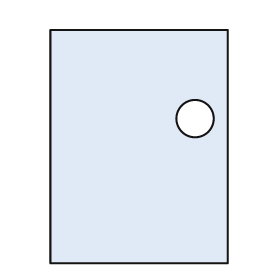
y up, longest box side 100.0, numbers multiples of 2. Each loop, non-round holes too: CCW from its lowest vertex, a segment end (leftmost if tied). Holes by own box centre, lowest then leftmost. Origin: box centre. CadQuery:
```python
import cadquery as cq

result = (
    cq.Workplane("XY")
    .moveTo(-38.0, -50.0)
    .lineTo(38.0, -50.0)
    .lineTo(38.0, 50.0)
    .lineTo(-38.0, 50.0)
    .close()
    .moveTo(24.0, 12.0)
    .circle(8.0)
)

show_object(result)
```